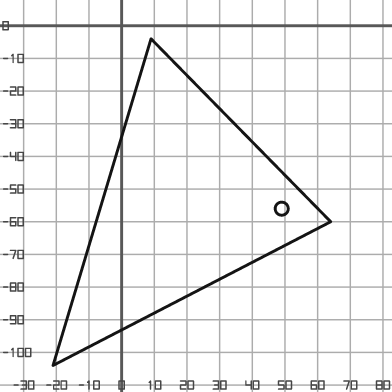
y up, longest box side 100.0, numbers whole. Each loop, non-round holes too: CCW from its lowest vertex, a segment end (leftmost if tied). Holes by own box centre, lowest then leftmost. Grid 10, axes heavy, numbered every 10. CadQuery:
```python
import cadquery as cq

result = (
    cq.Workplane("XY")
    .moveTo(-21.0, -104.0)
    .lineTo(64.0, -60.0)
    .lineTo(9.0, -4.0)
    .close()
    .moveTo(49.0, -56.0)
    .circle(2.0)
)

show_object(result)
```